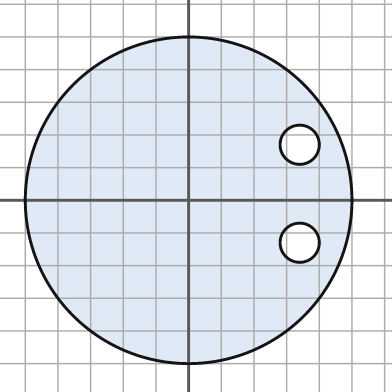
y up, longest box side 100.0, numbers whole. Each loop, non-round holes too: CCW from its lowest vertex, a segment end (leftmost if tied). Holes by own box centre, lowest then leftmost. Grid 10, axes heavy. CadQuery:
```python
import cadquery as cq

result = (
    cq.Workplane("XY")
    .moveTo(0.0, 0.0)
    .circle(50.0)
    .moveTo(34.0, -13.0)
    .circle(6.0)
    .moveTo(34.0, 17.0)
    .circle(6.0)
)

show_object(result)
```